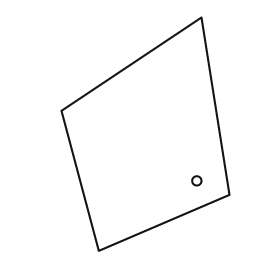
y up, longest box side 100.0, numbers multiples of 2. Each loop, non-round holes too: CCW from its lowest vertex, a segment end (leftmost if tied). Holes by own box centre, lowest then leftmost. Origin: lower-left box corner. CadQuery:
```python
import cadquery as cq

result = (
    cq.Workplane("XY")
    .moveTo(16.0, 0.0)
    .lineTo(72.0, 24.0)
    .lineTo(60.0, 100.0)
    .lineTo(0.0, 60.0)
    .close()
    .moveTo(58.0, 30.0)
    .circle(2.0)
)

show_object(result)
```